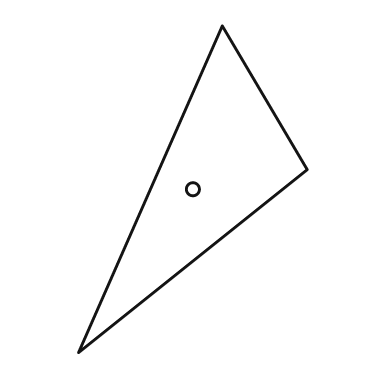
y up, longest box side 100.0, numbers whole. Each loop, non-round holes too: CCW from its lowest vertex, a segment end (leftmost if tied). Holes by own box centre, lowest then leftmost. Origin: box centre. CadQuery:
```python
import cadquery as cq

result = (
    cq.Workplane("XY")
    .moveTo(-35.0, -50.0)
    .lineTo(35.0, 6.0)
    .lineTo(9.0, 50.0)
    .close()
    .moveTo(0.0, 0.0)
    .circle(2.0)
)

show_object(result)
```